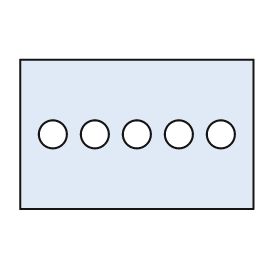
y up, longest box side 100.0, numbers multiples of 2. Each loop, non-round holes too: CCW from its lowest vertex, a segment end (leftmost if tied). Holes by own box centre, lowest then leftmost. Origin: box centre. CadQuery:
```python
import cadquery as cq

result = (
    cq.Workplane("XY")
    .moveTo(-50.0, -32.0)
    .lineTo(50.0, -32.0)
    .lineTo(50.0, 32.0)
    .lineTo(-50.0, 32.0)
    .close()
    .moveTo(-36.0, 0.0)
    .circle(6.0)
    .moveTo(-18.0, 0.0)
    .circle(6.0)
    .moveTo(0.0, 0.0)
    .circle(6.0)
    .moveTo(18.0, 0.0)
    .circle(6.0)
    .moveTo(36.0, 0.0)
    .circle(6.0)
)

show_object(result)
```